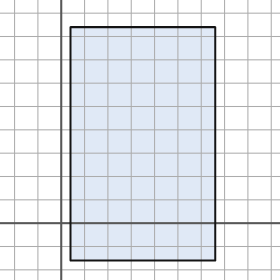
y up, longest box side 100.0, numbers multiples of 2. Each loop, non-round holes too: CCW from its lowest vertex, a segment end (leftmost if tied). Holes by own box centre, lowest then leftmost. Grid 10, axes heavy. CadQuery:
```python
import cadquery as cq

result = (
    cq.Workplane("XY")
    .moveTo(4.0, -16.0)
    .lineTo(66.0, -16.0)
    .lineTo(66.0, 84.0)
    .lineTo(4.0, 84.0)
    .close()
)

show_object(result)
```